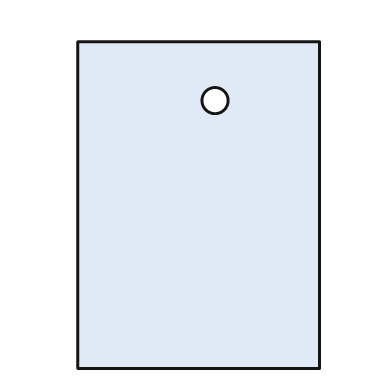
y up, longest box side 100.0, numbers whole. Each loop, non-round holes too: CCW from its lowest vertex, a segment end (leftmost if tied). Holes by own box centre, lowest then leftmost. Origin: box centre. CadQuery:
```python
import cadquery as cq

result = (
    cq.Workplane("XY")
    .moveTo(-37.0, -50.0)
    .lineTo(37.0, -50.0)
    .lineTo(37.0, 50.0)
    .lineTo(-37.0, 50.0)
    .close()
    .moveTo(5.0, 32.0)
    .circle(4.0)
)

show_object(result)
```